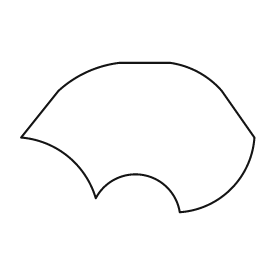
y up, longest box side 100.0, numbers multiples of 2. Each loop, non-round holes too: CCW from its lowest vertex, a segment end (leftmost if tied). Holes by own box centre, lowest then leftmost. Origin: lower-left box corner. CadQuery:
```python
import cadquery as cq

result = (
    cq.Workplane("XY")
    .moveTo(68.0, 0.0)
    .threePointArc((90.0, 10.0), (100.0, 32.0))
    .lineTo(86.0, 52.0)
    .threePointArc((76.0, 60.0), (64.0, 64.0))
    .lineTo(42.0, 64.0)
    .threePointArc((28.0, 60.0), (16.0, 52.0))
    .lineTo(0.0, 32.0)
    .threePointArc((20.0, 24.0), (32.0, 6.0))
    .threePointArc((52.0, 16.0), (68.0, 0.0))
    .close()
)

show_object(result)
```